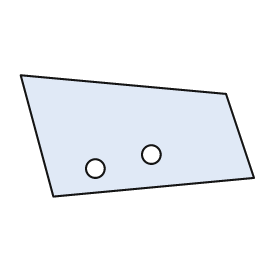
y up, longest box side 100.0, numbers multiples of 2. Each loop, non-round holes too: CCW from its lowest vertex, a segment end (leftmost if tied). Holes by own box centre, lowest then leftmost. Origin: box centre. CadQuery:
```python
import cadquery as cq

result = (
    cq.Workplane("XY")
    .moveTo(-36.0, -26.0)
    .lineTo(50.0, -18.0)
    .lineTo(38.0, 18.0)
    .lineTo(-50.0, 26.0)
    .close()
    .moveTo(-18.0, -14.0)
    .circle(4.0)
    .moveTo(6.0, -8.0)
    .circle(4.0)
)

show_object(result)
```